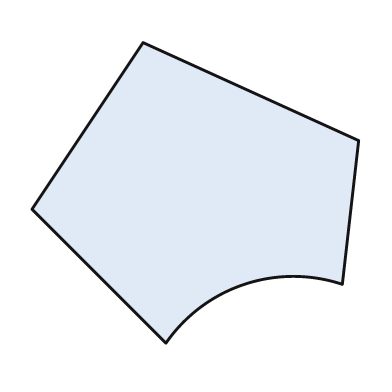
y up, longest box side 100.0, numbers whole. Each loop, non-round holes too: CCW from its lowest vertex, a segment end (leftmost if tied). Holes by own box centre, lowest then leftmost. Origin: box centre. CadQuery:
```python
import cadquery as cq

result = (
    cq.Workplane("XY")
    .moveTo(-9.0, -46.0)
    .threePointArc((15.0, -28.0), (45.0, -28.0))
    .lineTo(50.0, 16.0)
    .lineTo(-16.0, 46.0)
    .lineTo(-50.0, -5.0)
    .close()
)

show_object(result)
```